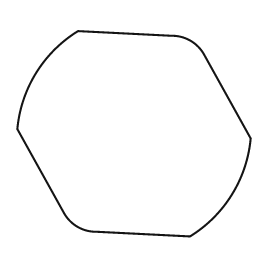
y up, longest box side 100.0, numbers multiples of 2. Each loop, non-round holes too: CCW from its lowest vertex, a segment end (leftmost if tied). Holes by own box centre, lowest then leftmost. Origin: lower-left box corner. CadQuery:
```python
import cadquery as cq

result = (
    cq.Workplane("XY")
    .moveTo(74.0, 0.0)
    .threePointArc((92.0, 18.0), (100.0, 42.0))
    .lineTo(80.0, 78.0)
    .threePointArc((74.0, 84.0), (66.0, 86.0))
    .lineTo(26.0, 88.0)
    .threePointArc((8.0, 70.0), (0.0, 46.0))
    .lineTo(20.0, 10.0)
    .threePointArc((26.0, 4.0), (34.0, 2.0))
    .close()
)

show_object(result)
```